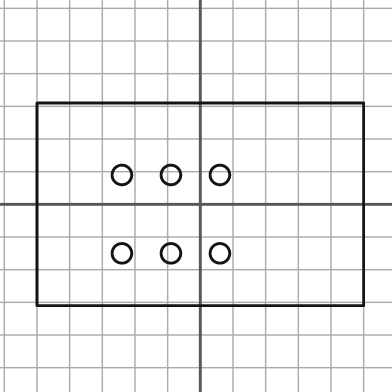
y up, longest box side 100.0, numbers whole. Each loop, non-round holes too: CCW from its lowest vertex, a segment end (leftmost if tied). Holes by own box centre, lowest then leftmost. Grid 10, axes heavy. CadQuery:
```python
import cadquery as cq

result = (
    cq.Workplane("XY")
    .moveTo(-50.0, -31.0)
    .lineTo(50.0, -31.0)
    .lineTo(50.0, 31.0)
    .lineTo(-50.0, 31.0)
    .close()
    .moveTo(-24.0, -15.0)
    .circle(3.0)
    .moveTo(-9.0, -15.0)
    .circle(3.0)
    .moveTo(6.0, -15.0)
    .circle(3.0)
    .moveTo(-24.0, 9.0)
    .circle(3.0)
    .moveTo(-9.0, 9.0)
    .circle(3.0)
    .moveTo(6.0, 9.0)
    .circle(3.0)
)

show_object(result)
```